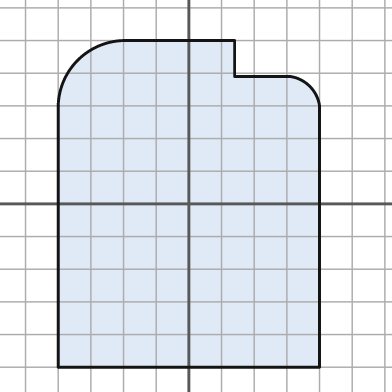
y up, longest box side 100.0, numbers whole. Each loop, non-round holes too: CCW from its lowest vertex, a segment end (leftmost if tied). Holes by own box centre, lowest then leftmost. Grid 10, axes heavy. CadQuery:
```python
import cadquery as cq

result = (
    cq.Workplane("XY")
    .moveTo(-40.0, -50.0)
    .lineTo(40.0, -50.0)
    .lineTo(40.0, 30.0)
    .threePointArc((37.0, 36.0), (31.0, 39.0))
    .lineTo(14.0, 39.0)
    .lineTo(14.0, 50.0)
    .lineTo(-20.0, 50.0)
    .threePointArc((-34.0, 44.0), (-40.0, 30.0))
    .close()
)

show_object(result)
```